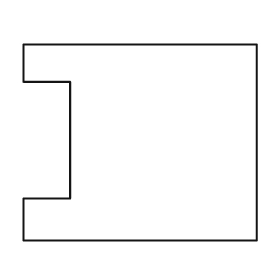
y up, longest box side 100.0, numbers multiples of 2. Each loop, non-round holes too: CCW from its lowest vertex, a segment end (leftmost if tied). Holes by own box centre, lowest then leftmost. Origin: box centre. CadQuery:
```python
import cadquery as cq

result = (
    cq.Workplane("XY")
    .moveTo(-50.0, -42.0)
    .lineTo(50.0, -42.0)
    .lineTo(50.0, 42.0)
    .lineTo(-50.0, 42.0)
    .lineTo(-50.0, 26.0)
    .lineTo(-30.0, 26.0)
    .lineTo(-30.0, -24.0)
    .lineTo(-50.0, -24.0)
    .close()
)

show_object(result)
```